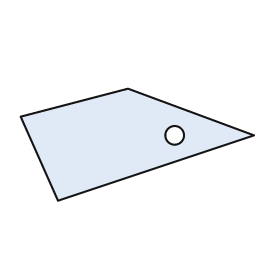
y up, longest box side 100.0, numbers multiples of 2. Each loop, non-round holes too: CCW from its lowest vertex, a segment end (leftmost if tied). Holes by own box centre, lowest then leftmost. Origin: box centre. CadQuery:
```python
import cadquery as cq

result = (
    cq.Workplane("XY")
    .moveTo(-34.0, -24.0)
    .lineTo(50.0, 4.0)
    .lineTo(-4.0, 24.0)
    .lineTo(-50.0, 12.0)
    .close()
    .moveTo(16.0, 4.0)
    .circle(4.0)
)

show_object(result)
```